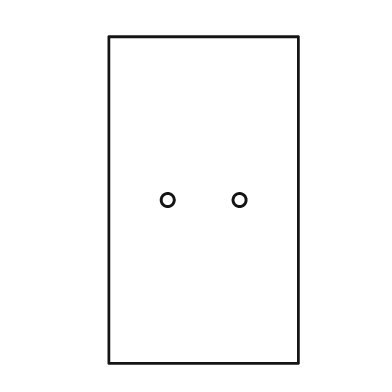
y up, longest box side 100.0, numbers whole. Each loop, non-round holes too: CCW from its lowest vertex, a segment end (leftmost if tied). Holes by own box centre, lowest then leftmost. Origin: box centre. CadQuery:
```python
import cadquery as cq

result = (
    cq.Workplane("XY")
    .moveTo(-29.0, -50.0)
    .lineTo(29.0, -50.0)
    .lineTo(29.0, 50.0)
    .lineTo(-29.0, 50.0)
    .close()
    .moveTo(-11.0, 0.0)
    .circle(2.0)
    .moveTo(11.0, 0.0)
    .circle(2.0)
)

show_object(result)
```